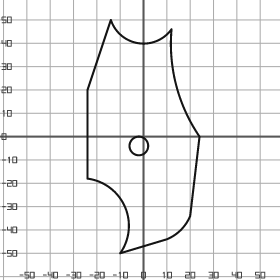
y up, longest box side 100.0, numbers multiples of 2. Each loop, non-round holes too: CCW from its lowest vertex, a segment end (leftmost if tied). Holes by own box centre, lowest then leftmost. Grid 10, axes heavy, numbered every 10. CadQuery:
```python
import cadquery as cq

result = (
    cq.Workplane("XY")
    .moveTo(-10.0, -50.0)
    .lineTo(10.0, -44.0)
    .threePointArc((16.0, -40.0), (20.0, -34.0))
    .lineTo(24.0, 0.0)
    .threePointArc((14.0, 22.0), (12.0, 46.0))
    .threePointArc((-2.0, 40.0), (-14.0, 50.0))
    .lineTo(-24.0, 20.0)
    .lineTo(-24.0, -18.0)
    .threePointArc((-8.0, -30.0), (-10.0, -50.0))
    .close()
    .moveTo(-2.0, -4.0)
    .circle(4.0)
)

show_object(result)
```